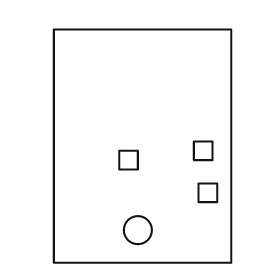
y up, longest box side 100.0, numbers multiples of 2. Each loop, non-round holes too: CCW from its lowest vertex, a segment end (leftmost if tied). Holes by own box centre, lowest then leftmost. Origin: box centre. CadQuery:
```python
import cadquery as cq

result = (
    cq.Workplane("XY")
    .moveTo(-38.0, -50.0)
    .lineTo(38.0, -50.0)
    .lineTo(38.0, 50.0)
    .lineTo(-38.0, 50.0)
    .close()
    .moveTo(-2.0, -36.0)
    .circle(6.0)
    .moveTo(24.0, -24.0)
    .lineTo(32.0, -24.0)
    .lineTo(32.0, -16.0)
    .lineTo(24.0, -16.0)
    .close()
    .moveTo(-10.0, -10.0)
    .lineTo(-2.0, -10.0)
    .lineTo(-2.0, -2.0)
    .lineTo(-10.0, -2.0)
    .close()
    .moveTo(22.0, -6.0)
    .lineTo(30.0, -6.0)
    .lineTo(30.0, 2.0)
    .lineTo(22.0, 2.0)
    .close()
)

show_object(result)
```